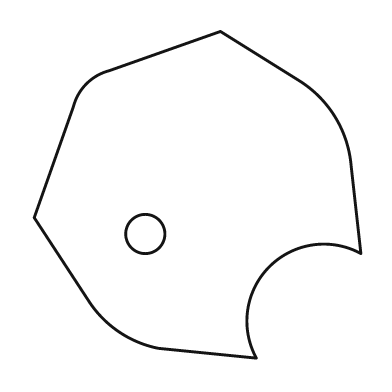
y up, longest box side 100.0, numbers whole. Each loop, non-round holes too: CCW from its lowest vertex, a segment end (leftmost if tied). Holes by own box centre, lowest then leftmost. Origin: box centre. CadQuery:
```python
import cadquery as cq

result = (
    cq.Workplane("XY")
    .moveTo(18.0, -50.0)
    .threePointArc((22.0, -22.0), (50.0, -18.0))
    .lineTo(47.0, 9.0)
    .threePointArc((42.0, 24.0), (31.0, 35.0))
    .lineTo(7.0, 50.0)
    .lineTo(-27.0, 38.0)
    .threePointArc((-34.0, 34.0), (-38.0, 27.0))
    .lineTo(-50.0, -7.0)
    .lineTo(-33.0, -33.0)
    .threePointArc((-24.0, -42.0), (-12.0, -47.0))
    .close()
    .moveTo(-16.0, -12.0)
    .circle(6.0)
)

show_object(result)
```